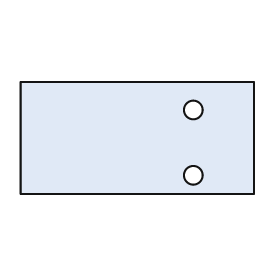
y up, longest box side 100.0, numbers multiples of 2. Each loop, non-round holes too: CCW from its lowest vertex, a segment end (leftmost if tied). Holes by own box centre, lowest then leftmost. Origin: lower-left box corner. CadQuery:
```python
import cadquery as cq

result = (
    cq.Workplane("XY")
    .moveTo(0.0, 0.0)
    .lineTo(100.0, 0.0)
    .lineTo(100.0, 48.0)
    .lineTo(0.0, 48.0)
    .close()
    .moveTo(74.0, 8.0)
    .circle(4.0)
    .moveTo(74.0, 36.0)
    .circle(4.0)
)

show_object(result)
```